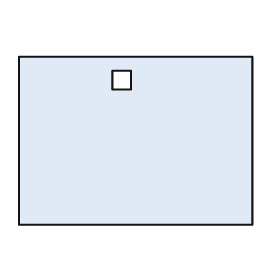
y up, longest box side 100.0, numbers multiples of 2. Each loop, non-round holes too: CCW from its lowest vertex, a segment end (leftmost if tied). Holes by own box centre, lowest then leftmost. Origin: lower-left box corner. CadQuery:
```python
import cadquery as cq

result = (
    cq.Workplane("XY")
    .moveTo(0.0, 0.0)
    .lineTo(100.0, 0.0)
    .lineTo(100.0, 72.0)
    .lineTo(0.0, 72.0)
    .close()
    .moveTo(40.0, 58.0)
    .lineTo(48.0, 58.0)
    .lineTo(48.0, 66.0)
    .lineTo(40.0, 66.0)
    .close()
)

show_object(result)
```